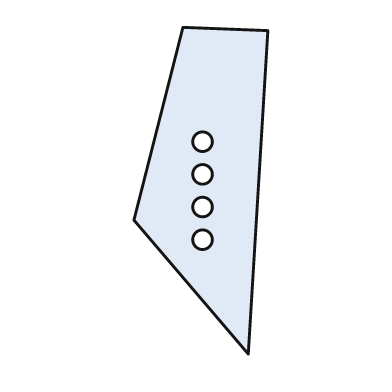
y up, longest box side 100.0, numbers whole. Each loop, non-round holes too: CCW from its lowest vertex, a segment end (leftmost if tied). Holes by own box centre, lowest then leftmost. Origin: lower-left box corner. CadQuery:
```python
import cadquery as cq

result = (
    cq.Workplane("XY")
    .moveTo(35.0, 0.0)
    .lineTo(41.0, 99.0)
    .lineTo(15.0, 100.0)
    .lineTo(0.0, 41.0)
    .close()
    .moveTo(21.0, 35.0)
    .circle(3.0)
    .moveTo(21.0, 45.0)
    .circle(3.0)
    .moveTo(21.0, 55.0)
    .circle(3.0)
    .moveTo(21.0, 65.0)
    .circle(3.0)
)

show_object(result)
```